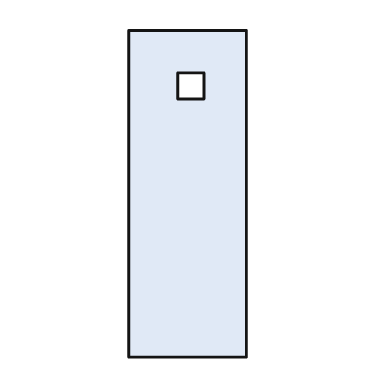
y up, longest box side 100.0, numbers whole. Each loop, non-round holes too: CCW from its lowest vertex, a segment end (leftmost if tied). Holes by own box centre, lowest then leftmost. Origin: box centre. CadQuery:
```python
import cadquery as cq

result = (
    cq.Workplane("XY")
    .moveTo(-18.0, -50.0)
    .lineTo(18.0, -50.0)
    .lineTo(18.0, 50.0)
    .lineTo(-18.0, 50.0)
    .close()
    .moveTo(-3.0, 29.0)
    .lineTo(5.0, 29.0)
    .lineTo(5.0, 37.0)
    .lineTo(-3.0, 37.0)
    .close()
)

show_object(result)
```